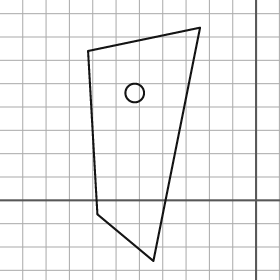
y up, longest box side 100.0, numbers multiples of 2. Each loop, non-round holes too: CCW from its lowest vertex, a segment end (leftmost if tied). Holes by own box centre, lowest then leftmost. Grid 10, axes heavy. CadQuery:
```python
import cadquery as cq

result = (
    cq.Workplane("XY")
    .moveTo(-44.0, -26.0)
    .lineTo(-24.0, 74.0)
    .lineTo(-72.0, 64.0)
    .lineTo(-68.0, -6.0)
    .close()
    .moveTo(-52.0, 46.0)
    .circle(4.0)
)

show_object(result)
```